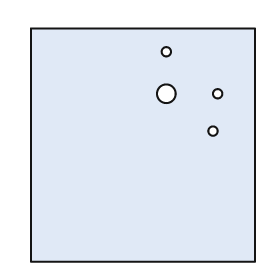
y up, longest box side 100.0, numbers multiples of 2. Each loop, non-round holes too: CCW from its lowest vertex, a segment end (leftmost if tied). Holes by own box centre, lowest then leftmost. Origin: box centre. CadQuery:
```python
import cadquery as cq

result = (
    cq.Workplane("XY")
    .moveTo(-48.0, -50.0)
    .lineTo(48.0, -50.0)
    .lineTo(48.0, 50.0)
    .lineTo(-48.0, 50.0)
    .close()
    .moveTo(30.0, 6.0)
    .circle(2.0)
    .moveTo(10.0, 22.0)
    .circle(4.0)
    .moveTo(32.0, 22.0)
    .circle(2.0)
    .moveTo(10.0, 40.0)
    .circle(2.0)
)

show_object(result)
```